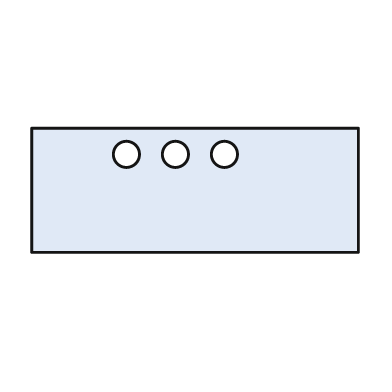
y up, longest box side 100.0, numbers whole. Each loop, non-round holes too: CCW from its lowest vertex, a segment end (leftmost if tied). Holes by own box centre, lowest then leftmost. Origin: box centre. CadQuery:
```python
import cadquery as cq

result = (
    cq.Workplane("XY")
    .moveTo(-50.0, -19.0)
    .lineTo(50.0, -19.0)
    .lineTo(50.0, 19.0)
    .lineTo(-50.0, 19.0)
    .close()
    .moveTo(-21.0, 11.0)
    .circle(4.0)
    .moveTo(-6.0, 11.0)
    .circle(4.0)
    .moveTo(9.0, 11.0)
    .circle(4.0)
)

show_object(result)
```